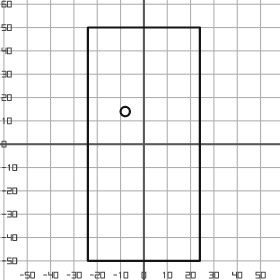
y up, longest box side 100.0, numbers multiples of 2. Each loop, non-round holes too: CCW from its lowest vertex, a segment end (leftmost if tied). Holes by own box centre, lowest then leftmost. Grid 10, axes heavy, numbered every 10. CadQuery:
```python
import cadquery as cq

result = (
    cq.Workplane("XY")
    .moveTo(-24.0, -50.0)
    .lineTo(24.0, -50.0)
    .lineTo(24.0, 50.0)
    .lineTo(-24.0, 50.0)
    .close()
    .moveTo(-8.0, 14.0)
    .circle(2.0)
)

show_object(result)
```